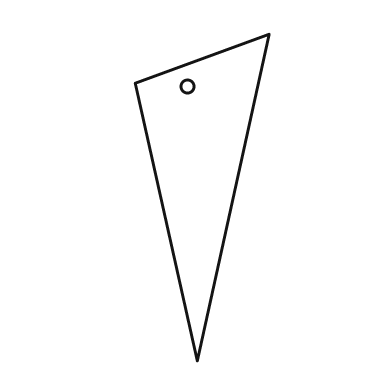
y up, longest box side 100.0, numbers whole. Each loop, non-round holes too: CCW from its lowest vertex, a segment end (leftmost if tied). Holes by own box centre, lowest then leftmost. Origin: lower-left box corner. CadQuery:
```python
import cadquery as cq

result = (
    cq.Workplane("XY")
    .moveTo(19.0, 0.0)
    .lineTo(41.0, 100.0)
    .lineTo(0.0, 85.0)
    .close()
    .moveTo(16.0, 84.0)
    .circle(2.0)
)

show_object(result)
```